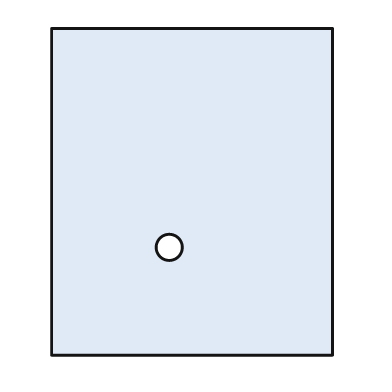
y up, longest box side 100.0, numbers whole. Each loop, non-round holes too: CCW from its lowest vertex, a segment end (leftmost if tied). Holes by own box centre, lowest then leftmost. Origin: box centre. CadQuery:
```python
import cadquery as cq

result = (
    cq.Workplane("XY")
    .moveTo(-43.0, -50.0)
    .lineTo(43.0, -50.0)
    .lineTo(43.0, 50.0)
    .lineTo(-43.0, 50.0)
    .close()
    .moveTo(-7.0, -17.0)
    .circle(4.0)
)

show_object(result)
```